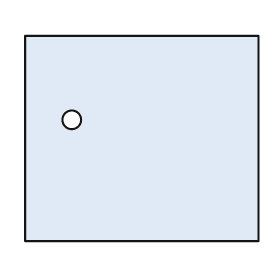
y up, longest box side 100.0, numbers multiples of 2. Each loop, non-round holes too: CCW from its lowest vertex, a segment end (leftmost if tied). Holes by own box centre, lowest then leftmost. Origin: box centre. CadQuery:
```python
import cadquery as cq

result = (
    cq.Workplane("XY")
    .moveTo(-50.0, -44.0)
    .lineTo(50.0, -44.0)
    .lineTo(50.0, 44.0)
    .lineTo(-50.0, 44.0)
    .close()
    .moveTo(-30.0, 8.0)
    .circle(4.0)
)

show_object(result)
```